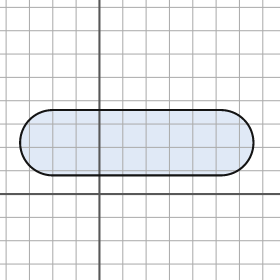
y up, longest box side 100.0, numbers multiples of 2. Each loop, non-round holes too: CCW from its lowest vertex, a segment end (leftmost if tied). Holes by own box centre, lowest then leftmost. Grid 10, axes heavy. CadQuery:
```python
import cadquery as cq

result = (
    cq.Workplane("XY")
    .moveTo(-20.0, 8.0)
    .lineTo(52.0, 8.0)
    .threePointArc((66.0, 22.0), (52.0, 36.0))
    .lineTo(-20.0, 36.0)
    .threePointArc((-34.0, 22.0), (-20.0, 8.0))
    .close()
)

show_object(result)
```